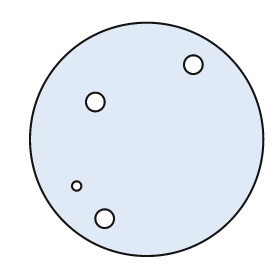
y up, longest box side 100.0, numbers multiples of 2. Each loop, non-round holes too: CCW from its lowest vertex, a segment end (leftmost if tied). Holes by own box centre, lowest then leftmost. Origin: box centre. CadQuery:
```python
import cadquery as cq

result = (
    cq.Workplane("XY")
    .moveTo(0.0, 0.0)
    .circle(50.0)
    .moveTo(-18.0, -34.0)
    .circle(4.0)
    .moveTo(-30.0, -20.0)
    .circle(2.0)
    .moveTo(-22.0, 16.0)
    .circle(4.0)
    .moveTo(20.0, 32.0)
    .circle(4.0)
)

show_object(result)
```